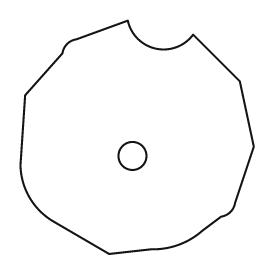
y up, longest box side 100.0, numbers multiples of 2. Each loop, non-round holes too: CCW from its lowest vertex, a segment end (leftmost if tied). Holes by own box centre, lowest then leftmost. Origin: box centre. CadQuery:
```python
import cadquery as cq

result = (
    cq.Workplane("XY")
    .moveTo(-12.0, -50.0)
    .lineTo(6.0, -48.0)
    .threePointArc((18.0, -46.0), (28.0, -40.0))
    .lineTo(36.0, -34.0)
    .threePointArc((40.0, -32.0), (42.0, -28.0))
    .lineTo(50.0, -4.0)
    .lineTo(44.0, 24.0)
    .lineTo(24.0, 44.0)
    .threePointArc((8.0, 38.0), (-4.0, 50.0))
    .lineTo(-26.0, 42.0)
    .threePointArc((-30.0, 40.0), (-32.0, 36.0))
    .lineTo(-48.0, 18.0)
    .lineTo(-50.0, -12.0)
    .threePointArc((-46.0, -26.0), (-36.0, -36.0))
    .close()
    .moveTo(-2.0, -8.0)
    .circle(6.0)
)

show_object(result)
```